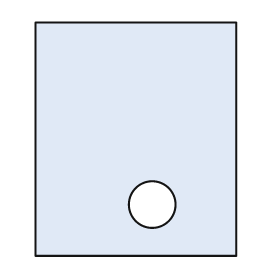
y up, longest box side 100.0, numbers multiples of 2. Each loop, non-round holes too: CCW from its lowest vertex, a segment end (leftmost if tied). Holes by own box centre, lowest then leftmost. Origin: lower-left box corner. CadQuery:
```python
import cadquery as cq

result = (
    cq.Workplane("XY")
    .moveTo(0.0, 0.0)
    .lineTo(86.0, 0.0)
    .lineTo(86.0, 100.0)
    .lineTo(0.0, 100.0)
    .close()
    .moveTo(50.0, 22.0)
    .circle(10.0)
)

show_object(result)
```